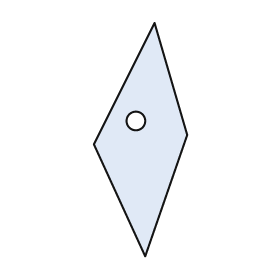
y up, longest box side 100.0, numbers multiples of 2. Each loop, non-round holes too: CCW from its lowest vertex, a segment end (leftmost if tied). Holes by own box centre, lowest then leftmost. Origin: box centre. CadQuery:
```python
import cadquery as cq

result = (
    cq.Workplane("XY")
    .moveTo(2.0, -50.0)
    .lineTo(20.0, 2.0)
    .lineTo(6.0, 50.0)
    .lineTo(-20.0, -2.0)
    .close()
    .moveTo(-2.0, 8.0)
    .circle(4.0)
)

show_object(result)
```